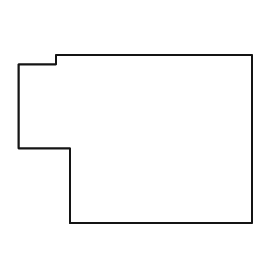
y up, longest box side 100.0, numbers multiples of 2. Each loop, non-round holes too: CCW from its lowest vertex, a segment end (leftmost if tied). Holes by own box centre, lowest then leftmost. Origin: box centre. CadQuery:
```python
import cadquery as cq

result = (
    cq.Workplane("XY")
    .moveTo(-28.0, -36.0)
    .lineTo(50.0, -36.0)
    .lineTo(50.0, 36.0)
    .lineTo(-34.0, 36.0)
    .lineTo(-34.0, 32.0)
    .lineTo(-50.0, 32.0)
    .lineTo(-50.0, -4.0)
    .lineTo(-28.0, -4.0)
    .close()
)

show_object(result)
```